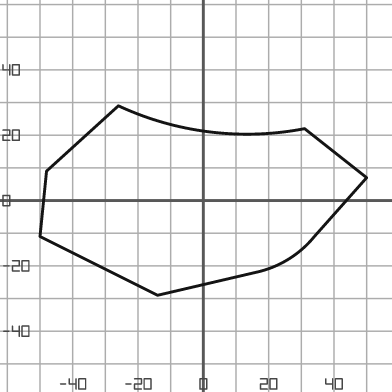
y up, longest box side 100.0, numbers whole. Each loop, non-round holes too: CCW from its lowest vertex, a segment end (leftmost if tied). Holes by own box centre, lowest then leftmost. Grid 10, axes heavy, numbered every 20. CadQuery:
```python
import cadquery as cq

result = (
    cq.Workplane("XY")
    .moveTo(-14.0, -29.0)
    .lineTo(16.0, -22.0)
    .threePointArc((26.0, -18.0), (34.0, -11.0))
    .lineTo(50.0, 7.0)
    .lineTo(31.0, 22.0)
    .threePointArc((2.0, 21.0), (-26.0, 29.0))
    .lineTo(-48.0, 9.0)
    .lineTo(-50.0, -11.0)
    .close()
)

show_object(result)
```